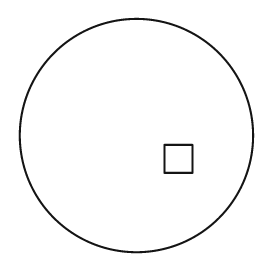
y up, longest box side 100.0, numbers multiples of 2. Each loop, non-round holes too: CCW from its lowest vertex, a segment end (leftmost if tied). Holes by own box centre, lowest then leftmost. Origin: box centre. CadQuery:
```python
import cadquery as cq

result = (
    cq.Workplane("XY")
    .moveTo(0.0, 0.0)
    .circle(50.0)
    .moveTo(12.0, -16.0)
    .lineTo(24.0, -16.0)
    .lineTo(24.0, -4.0)
    .lineTo(12.0, -4.0)
    .close()
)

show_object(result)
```